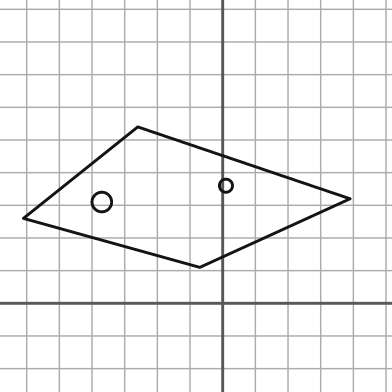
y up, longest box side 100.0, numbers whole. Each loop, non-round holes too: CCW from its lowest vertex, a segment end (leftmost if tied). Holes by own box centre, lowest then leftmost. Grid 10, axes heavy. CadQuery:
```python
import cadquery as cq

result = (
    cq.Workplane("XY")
    .moveTo(-7.0, 11.0)
    .lineTo(39.0, 32.0)
    .lineTo(-26.0, 54.0)
    .lineTo(-61.0, 26.0)
    .close()
    .moveTo(-37.0, 31.0)
    .circle(3.0)
    .moveTo(1.0, 36.0)
    .circle(2.0)
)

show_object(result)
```